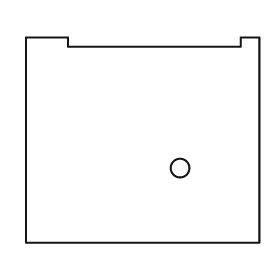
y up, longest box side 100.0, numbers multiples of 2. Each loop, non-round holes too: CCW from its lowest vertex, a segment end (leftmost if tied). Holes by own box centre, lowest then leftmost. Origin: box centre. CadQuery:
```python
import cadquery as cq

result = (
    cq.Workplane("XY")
    .moveTo(-50.0, -44.0)
    .lineTo(50.0, -44.0)
    .lineTo(50.0, 44.0)
    .lineTo(42.0, 44.0)
    .lineTo(42.0, 40.0)
    .lineTo(-32.0, 40.0)
    .lineTo(-32.0, 44.0)
    .lineTo(-50.0, 44.0)
    .close()
    .moveTo(16.0, -12.0)
    .circle(4.0)
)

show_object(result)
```